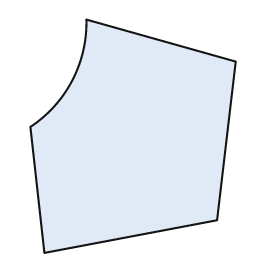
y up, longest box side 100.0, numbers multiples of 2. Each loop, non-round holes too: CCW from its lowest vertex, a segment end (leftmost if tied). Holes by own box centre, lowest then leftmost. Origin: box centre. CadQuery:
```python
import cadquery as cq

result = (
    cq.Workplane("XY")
    .moveTo(-38.0, -50.0)
    .lineTo(36.0, -36.0)
    .lineTo(44.0, 32.0)
    .lineTo(-20.0, 50.0)
    .threePointArc((-26.0, 24.0), (-44.0, 4.0))
    .close()
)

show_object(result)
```